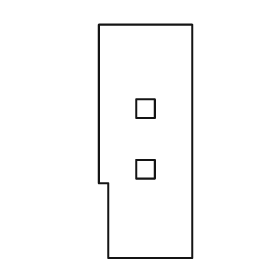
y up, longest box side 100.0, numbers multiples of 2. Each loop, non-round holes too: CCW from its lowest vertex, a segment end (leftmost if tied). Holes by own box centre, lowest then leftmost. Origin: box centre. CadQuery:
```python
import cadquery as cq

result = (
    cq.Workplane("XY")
    .moveTo(-16.0, -50.0)
    .lineTo(20.0, -50.0)
    .lineTo(20.0, 50.0)
    .lineTo(-20.0, 50.0)
    .lineTo(-20.0, -18.0)
    .lineTo(-16.0, -18.0)
    .close()
    .moveTo(-4.0, -16.0)
    .lineTo(4.0, -16.0)
    .lineTo(4.0, -8.0)
    .lineTo(-4.0, -8.0)
    .close()
    .moveTo(-4.0, 10.0)
    .lineTo(4.0, 10.0)
    .lineTo(4.0, 18.0)
    .lineTo(-4.0, 18.0)
    .close()
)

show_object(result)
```